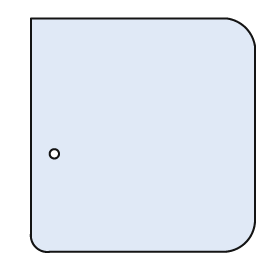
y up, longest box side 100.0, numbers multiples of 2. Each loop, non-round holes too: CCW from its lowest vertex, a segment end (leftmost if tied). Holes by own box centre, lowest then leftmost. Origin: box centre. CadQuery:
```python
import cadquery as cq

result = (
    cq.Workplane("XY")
    .moveTo(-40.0, -50.0)
    .lineTo(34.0, -50.0)
    .threePointArc((44.0, -46.0), (48.0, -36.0))
    .lineTo(48.0, 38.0)
    .threePointArc((44.0, 46.0), (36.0, 50.0))
    .lineTo(-48.0, 50.0)
    .lineTo(-48.0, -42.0)
    .threePointArc((-46.0, -48.0), (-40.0, -50.0))
    .close()
    .moveTo(-38.0, -8.0)
    .circle(2.0)
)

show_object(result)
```